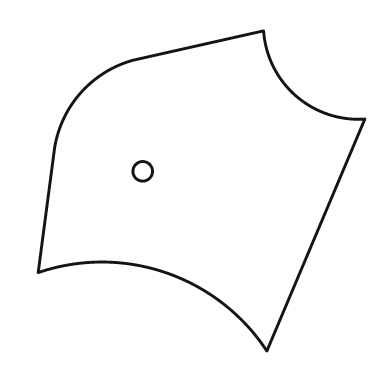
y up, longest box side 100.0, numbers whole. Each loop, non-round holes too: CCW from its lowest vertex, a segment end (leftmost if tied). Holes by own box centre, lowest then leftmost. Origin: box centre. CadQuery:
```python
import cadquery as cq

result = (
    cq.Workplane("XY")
    .moveTo(20.0, -49.0)
    .lineTo(50.0, 22.0)
    .threePointArc((29.0, 29.0), (19.0, 49.0))
    .lineTo(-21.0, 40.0)
    .threePointArc((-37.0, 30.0), (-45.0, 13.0))
    .lineTo(-50.0, -25.0)
    .threePointArc((-11.0, -25.0), (20.0, -49.0))
    .close()
    .moveTo(-18.0, 6.0)
    .circle(3.0)
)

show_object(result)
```